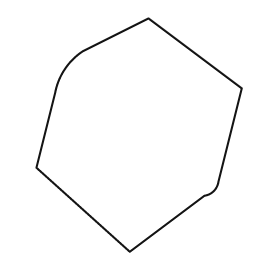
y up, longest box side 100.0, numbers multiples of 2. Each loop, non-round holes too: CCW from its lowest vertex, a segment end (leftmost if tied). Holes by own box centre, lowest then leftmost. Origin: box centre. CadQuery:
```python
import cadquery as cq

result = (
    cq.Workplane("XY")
    .moveTo(-4.0, -50.0)
    .lineTo(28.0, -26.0)
    .threePointArc((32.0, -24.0), (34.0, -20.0))
    .lineTo(44.0, 20.0)
    .lineTo(4.0, 50.0)
    .lineTo(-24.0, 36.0)
    .threePointArc((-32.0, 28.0), (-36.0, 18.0))
    .lineTo(-44.0, -14.0)
    .close()
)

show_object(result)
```